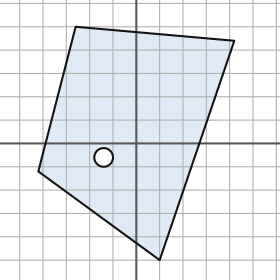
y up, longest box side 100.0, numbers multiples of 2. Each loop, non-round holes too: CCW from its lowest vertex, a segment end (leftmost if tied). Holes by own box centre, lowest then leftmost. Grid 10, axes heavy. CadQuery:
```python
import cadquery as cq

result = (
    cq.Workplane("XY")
    .moveTo(10.0, -50.0)
    .lineTo(42.0, 44.0)
    .lineTo(-26.0, 50.0)
    .lineTo(-42.0, -12.0)
    .close()
    .moveTo(-14.0, -6.0)
    .circle(4.0)
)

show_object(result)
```